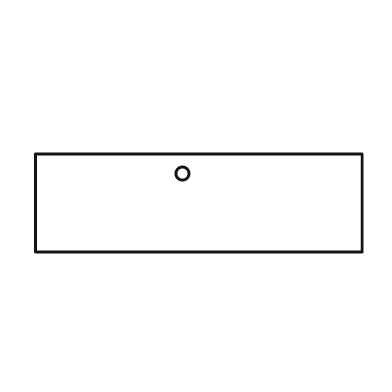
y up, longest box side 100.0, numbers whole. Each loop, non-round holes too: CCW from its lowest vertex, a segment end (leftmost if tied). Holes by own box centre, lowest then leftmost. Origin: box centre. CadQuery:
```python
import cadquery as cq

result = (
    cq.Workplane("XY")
    .moveTo(-50.0, -15.0)
    .lineTo(50.0, -15.0)
    .lineTo(50.0, 15.0)
    .lineTo(-50.0, 15.0)
    .close()
    .moveTo(-5.0, 9.0)
    .circle(2.0)
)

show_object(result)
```